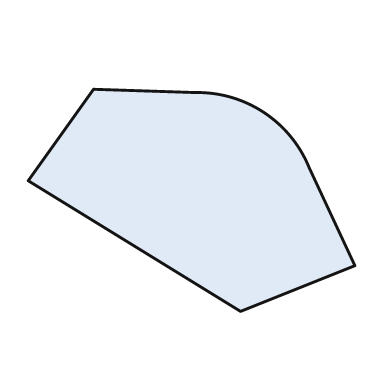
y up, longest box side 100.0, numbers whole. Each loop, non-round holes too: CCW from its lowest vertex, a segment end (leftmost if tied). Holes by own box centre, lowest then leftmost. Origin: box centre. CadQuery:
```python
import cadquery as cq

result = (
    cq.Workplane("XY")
    .moveTo(15.0, -34.0)
    .lineTo(50.0, -20.0)
    .lineTo(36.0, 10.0)
    .threePointArc((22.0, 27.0), (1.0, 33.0))
    .lineTo(-30.0, 34.0)
    .lineTo(-50.0, 6.0)
    .close()
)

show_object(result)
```